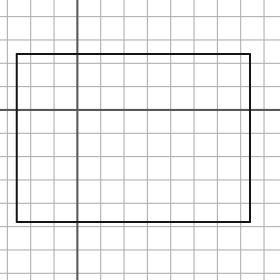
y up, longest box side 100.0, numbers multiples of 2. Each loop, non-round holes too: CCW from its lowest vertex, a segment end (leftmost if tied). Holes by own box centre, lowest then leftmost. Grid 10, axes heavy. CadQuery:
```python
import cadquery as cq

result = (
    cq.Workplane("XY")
    .moveTo(-26.0, -48.0)
    .lineTo(74.0, -48.0)
    .lineTo(74.0, 24.0)
    .lineTo(-26.0, 24.0)
    .close()
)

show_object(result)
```